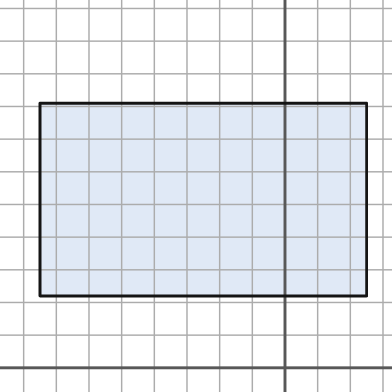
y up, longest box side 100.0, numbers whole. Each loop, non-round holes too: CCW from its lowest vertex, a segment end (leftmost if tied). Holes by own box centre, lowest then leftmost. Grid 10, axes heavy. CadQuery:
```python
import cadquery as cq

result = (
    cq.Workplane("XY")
    .moveTo(-75.0, 22.0)
    .lineTo(25.0, 22.0)
    .lineTo(25.0, 81.0)
    .lineTo(-75.0, 81.0)
    .close()
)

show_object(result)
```